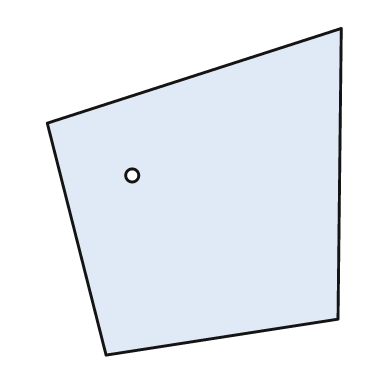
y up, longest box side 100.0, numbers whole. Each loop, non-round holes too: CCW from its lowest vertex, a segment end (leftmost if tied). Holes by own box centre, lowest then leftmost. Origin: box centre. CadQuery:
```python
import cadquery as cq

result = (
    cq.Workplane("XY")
    .moveTo(-27.0, -50.0)
    .lineTo(44.0, -39.0)
    .lineTo(45.0, 50.0)
    .lineTo(-45.0, 21.0)
    .close()
    .moveTo(-19.0, 5.0)
    .circle(2.0)
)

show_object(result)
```